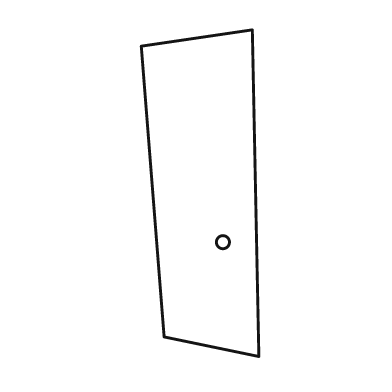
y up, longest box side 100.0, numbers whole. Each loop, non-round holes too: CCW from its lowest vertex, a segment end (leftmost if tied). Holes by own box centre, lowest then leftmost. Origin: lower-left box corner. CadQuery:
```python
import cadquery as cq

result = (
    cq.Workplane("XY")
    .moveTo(36.0, 0.0)
    .lineTo(34.0, 100.0)
    .lineTo(0.0, 95.0)
    .lineTo(7.0, 6.0)
    .close()
    .moveTo(25.0, 35.0)
    .circle(2.0)
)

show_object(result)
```